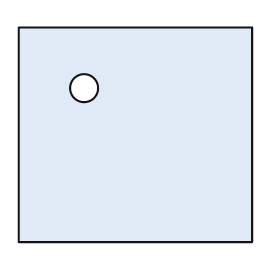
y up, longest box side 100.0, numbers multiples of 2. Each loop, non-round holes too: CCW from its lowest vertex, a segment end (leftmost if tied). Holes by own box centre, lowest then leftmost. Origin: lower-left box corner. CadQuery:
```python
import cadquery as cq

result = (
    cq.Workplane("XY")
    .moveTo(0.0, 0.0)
    .lineTo(100.0, 0.0)
    .lineTo(100.0, 92.0)
    .lineTo(0.0, 92.0)
    .close()
    .moveTo(28.0, 66.0)
    .circle(6.0)
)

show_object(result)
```